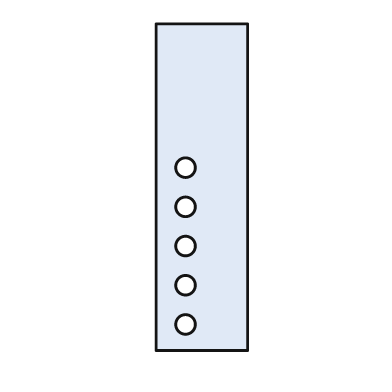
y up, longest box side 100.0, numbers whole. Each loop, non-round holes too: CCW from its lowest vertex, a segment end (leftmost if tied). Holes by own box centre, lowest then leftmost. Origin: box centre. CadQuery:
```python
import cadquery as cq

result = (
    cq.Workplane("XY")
    .moveTo(-14.0, -50.0)
    .lineTo(14.0, -50.0)
    .lineTo(14.0, 50.0)
    .lineTo(-14.0, 50.0)
    .close()
    .moveTo(-5.0, -42.0)
    .circle(3.0)
    .moveTo(-5.0, -30.0)
    .circle(3.0)
    .moveTo(-5.0, -18.0)
    .circle(3.0)
    .moveTo(-5.0, -6.0)
    .circle(3.0)
    .moveTo(-5.0, 6.0)
    .circle(3.0)
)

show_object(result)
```